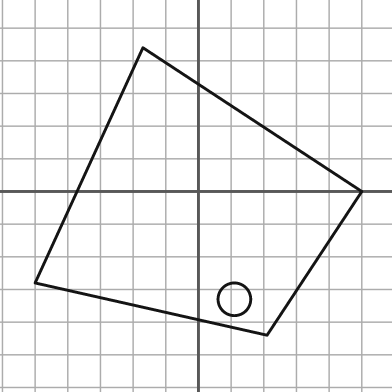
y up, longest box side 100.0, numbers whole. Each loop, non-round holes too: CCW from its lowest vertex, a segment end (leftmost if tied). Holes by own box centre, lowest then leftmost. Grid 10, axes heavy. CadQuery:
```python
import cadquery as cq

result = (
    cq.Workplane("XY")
    .moveTo(21.0, -44.0)
    .lineTo(50.0, 0.0)
    .lineTo(-17.0, 44.0)
    .lineTo(-50.0, -28.0)
    .close()
    .moveTo(11.0, -33.0)
    .circle(5.0)
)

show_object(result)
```